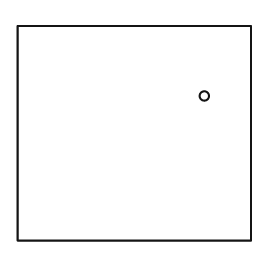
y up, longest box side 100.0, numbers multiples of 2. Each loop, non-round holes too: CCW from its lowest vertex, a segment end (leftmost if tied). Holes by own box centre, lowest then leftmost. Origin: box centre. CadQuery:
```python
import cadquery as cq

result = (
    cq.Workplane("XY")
    .moveTo(-50.0, -46.0)
    .lineTo(50.0, -46.0)
    .lineTo(50.0, 46.0)
    .lineTo(-50.0, 46.0)
    .close()
    .moveTo(30.0, 16.0)
    .circle(2.0)
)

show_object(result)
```